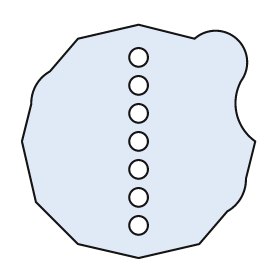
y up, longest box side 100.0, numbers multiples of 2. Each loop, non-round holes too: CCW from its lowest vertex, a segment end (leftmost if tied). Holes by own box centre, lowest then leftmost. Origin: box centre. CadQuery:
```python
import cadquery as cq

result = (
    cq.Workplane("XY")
    .moveTo(0.0, -50.0)
    .lineTo(26.0, -44.0)
    .lineTo(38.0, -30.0)
    .threePointArc((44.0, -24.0), (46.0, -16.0))
    .lineTo(50.0, 0.0)
    .threePointArc((42.0, 12.0), (44.0, 26.0))
    .threePointArc((42.0, 44.0), (24.0, 44.0))
    .lineTo(0.0, 50.0)
    .lineTo(-26.0, 44.0)
    .lineTo(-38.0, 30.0)
    .threePointArc((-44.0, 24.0), (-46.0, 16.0))
    .lineTo(-50.0, 0.0)
    .lineTo(-44.0, -26.0)
    .lineTo(-26.0, -44.0)
    .close()
    .moveTo(0.0, -36.0)
    .circle(4.0)
    .moveTo(0.0, -24.0)
    .circle(4.0)
    .moveTo(0.0, -12.0)
    .circle(4.0)
    .moveTo(0.0, 0.0)
    .circle(4.0)
    .moveTo(0.0, 12.0)
    .circle(4.0)
    .moveTo(0.0, 24.0)
    .circle(4.0)
    .moveTo(0.0, 36.0)
    .circle(4.0)
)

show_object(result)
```